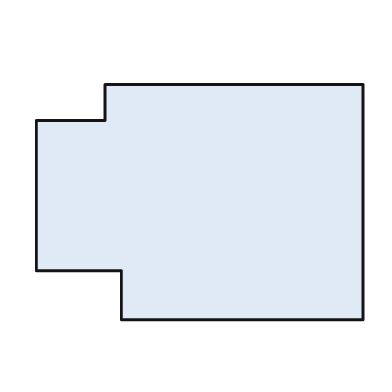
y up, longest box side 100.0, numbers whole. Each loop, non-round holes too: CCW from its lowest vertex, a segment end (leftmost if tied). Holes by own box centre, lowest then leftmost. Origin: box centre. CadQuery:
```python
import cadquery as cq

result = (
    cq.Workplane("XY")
    .moveTo(-24.0, -36.0)
    .lineTo(50.0, -36.0)
    .lineTo(50.0, 36.0)
    .lineTo(-29.0, 36.0)
    .lineTo(-29.0, 25.0)
    .lineTo(-50.0, 25.0)
    .lineTo(-50.0, -21.0)
    .lineTo(-24.0, -21.0)
    .close()
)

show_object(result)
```